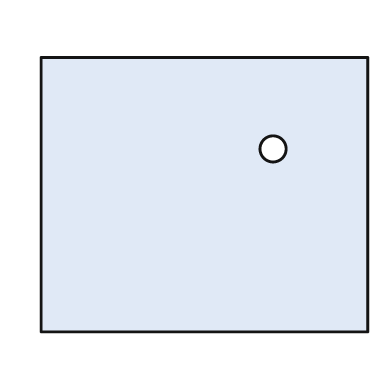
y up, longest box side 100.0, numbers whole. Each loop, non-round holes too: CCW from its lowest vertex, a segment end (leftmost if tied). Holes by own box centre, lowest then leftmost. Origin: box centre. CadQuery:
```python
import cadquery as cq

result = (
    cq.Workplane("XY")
    .moveTo(-50.0, -42.0)
    .lineTo(50.0, -42.0)
    .lineTo(50.0, 42.0)
    .lineTo(-50.0, 42.0)
    .close()
    .moveTo(21.0, 14.0)
    .circle(4.0)
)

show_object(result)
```